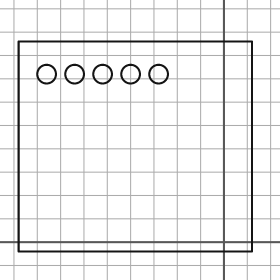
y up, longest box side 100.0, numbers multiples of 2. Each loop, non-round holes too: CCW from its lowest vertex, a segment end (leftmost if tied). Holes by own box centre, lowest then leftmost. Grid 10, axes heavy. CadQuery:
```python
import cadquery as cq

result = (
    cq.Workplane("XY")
    .moveTo(-88.0, -4.0)
    .lineTo(12.0, -4.0)
    .lineTo(12.0, 86.0)
    .lineTo(-88.0, 86.0)
    .close()
    .moveTo(-76.0, 72.0)
    .circle(4.0)
    .moveTo(-64.0, 72.0)
    .circle(4.0)
    .moveTo(-52.0, 72.0)
    .circle(4.0)
    .moveTo(-40.0, 72.0)
    .circle(4.0)
    .moveTo(-28.0, 72.0)
    .circle(4.0)
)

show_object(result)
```